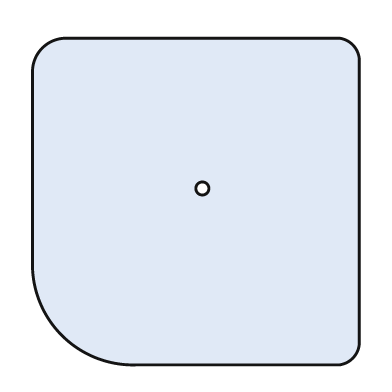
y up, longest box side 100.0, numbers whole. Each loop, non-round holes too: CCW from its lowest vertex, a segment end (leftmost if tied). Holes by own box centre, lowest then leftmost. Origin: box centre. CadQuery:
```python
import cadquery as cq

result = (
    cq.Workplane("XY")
    .moveTo(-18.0, -50.0)
    .lineTo(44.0, -50.0)
    .threePointArc((48.0, -48.0), (50.0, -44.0))
    .lineTo(50.0, 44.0)
    .threePointArc((48.0, 48.0), (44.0, 50.0))
    .lineTo(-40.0, 50.0)
    .threePointArc((-47.0, 47.0), (-50.0, 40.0))
    .lineTo(-50.0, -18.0)
    .threePointArc((-41.0, -41.0), (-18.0, -50.0))
    .close()
    .moveTo(2.0, 4.0)
    .circle(2.0)
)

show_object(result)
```